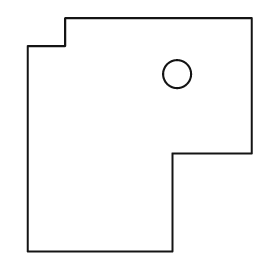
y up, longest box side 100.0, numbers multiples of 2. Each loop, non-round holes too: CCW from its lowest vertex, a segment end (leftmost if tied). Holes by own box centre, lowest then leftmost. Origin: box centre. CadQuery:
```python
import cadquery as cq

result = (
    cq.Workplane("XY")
    .moveTo(-48.0, -50.0)
    .lineTo(14.0, -50.0)
    .lineTo(14.0, -8.0)
    .lineTo(48.0, -8.0)
    .lineTo(48.0, 50.0)
    .lineTo(-32.0, 50.0)
    .lineTo(-32.0, 38.0)
    .lineTo(-48.0, 38.0)
    .close()
    .moveTo(16.0, 26.0)
    .circle(6.0)
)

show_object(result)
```